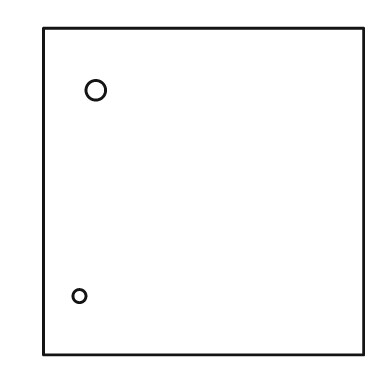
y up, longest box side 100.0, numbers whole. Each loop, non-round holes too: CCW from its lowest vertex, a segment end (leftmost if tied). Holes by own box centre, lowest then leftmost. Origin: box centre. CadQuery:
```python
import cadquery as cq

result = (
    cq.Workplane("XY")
    .moveTo(-49.0, -50.0)
    .lineTo(49.0, -50.0)
    .lineTo(49.0, 50.0)
    .lineTo(-49.0, 50.0)
    .close()
    .moveTo(-38.0, -32.0)
    .circle(2.0)
    .moveTo(-33.0, 31.0)
    .circle(3.0)
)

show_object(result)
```